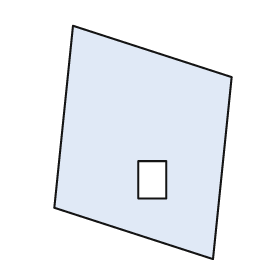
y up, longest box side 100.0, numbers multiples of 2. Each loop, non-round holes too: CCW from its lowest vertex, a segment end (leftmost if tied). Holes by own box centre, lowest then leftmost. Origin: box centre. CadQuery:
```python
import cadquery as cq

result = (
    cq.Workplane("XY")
    .moveTo(30.0, -50.0)
    .lineTo(38.0, 28.0)
    .lineTo(-30.0, 50.0)
    .lineTo(-38.0, -28.0)
    .close()
    .moveTo(-2.0, -24.0)
    .lineTo(10.0, -24.0)
    .lineTo(10.0, -8.0)
    .lineTo(-2.0, -8.0)
    .close()
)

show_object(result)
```